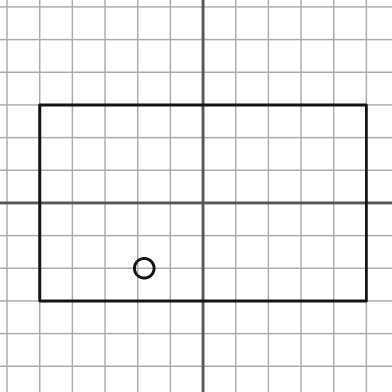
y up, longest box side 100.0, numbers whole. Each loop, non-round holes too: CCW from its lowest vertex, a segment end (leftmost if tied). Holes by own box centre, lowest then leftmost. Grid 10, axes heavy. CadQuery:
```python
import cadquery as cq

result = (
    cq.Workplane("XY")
    .moveTo(-50.0, -30.0)
    .lineTo(50.0, -30.0)
    .lineTo(50.0, 30.0)
    .lineTo(-50.0, 30.0)
    .close()
    .moveTo(-18.0, -20.0)
    .circle(3.0)
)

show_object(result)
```